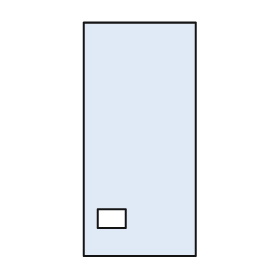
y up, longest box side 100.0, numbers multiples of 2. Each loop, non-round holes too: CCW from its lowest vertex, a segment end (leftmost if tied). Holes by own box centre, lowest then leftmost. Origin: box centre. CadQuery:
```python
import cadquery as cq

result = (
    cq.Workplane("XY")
    .moveTo(-24.0, -50.0)
    .lineTo(24.0, -50.0)
    .lineTo(24.0, 50.0)
    .lineTo(-24.0, 50.0)
    .close()
    .moveTo(-18.0, -38.0)
    .lineTo(-6.0, -38.0)
    .lineTo(-6.0, -30.0)
    .lineTo(-18.0, -30.0)
    .close()
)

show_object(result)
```